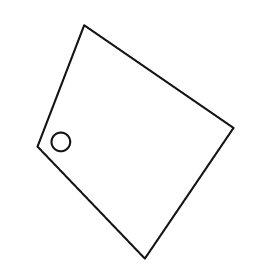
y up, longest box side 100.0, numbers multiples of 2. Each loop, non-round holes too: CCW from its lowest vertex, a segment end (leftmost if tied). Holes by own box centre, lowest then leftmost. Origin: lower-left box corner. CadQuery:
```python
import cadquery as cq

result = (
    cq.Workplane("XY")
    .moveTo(46.0, 0.0)
    .lineTo(84.0, 56.0)
    .lineTo(20.0, 100.0)
    .lineTo(0.0, 48.0)
    .close()
    .moveTo(10.0, 50.0)
    .circle(4.0)
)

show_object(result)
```